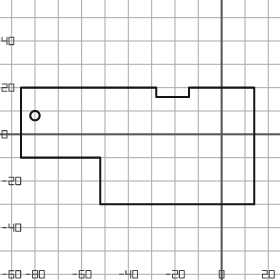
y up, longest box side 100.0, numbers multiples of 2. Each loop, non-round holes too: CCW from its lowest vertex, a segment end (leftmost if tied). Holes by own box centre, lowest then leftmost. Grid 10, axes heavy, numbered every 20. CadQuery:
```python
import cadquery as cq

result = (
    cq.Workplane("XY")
    .moveTo(-52.0, -30.0)
    .lineTo(14.0, -30.0)
    .lineTo(14.0, 20.0)
    .lineTo(-14.0, 20.0)
    .lineTo(-14.0, 16.0)
    .lineTo(-28.0, 16.0)
    .lineTo(-28.0, 20.0)
    .lineTo(-86.0, 20.0)
    .lineTo(-86.0, -10.0)
    .lineTo(-52.0, -10.0)
    .close()
    .moveTo(-80.0, 8.0)
    .circle(2.0)
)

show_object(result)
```